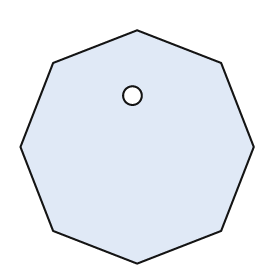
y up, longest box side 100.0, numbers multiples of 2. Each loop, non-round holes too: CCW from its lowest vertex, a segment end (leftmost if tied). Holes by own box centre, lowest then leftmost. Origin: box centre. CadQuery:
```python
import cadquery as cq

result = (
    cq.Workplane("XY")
    .moveTo(0.0, -50.0)
    .lineTo(36.0, -36.0)
    .lineTo(50.0, 0.0)
    .lineTo(36.0, 36.0)
    .lineTo(0.0, 50.0)
    .lineTo(-36.0, 36.0)
    .lineTo(-50.0, 0.0)
    .lineTo(-36.0, -36.0)
    .close()
    .moveTo(-2.0, 22.0)
    .circle(4.0)
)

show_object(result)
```